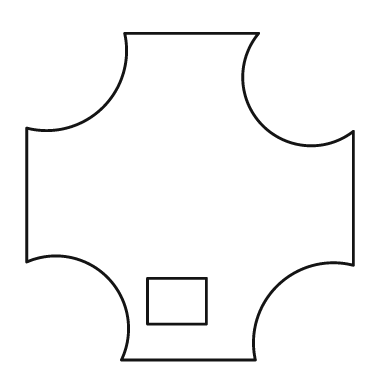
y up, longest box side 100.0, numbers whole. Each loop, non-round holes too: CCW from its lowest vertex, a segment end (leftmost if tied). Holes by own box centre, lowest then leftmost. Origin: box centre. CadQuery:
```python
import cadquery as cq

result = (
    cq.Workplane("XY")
    .moveTo(-21.0, -50.0)
    .lineTo(20.0, -50.0)
    .threePointArc((27.0, -27.0), (50.0, -21.0))
    .lineTo(50.0, 20.0)
    .threePointArc((22.0, 22.0), (21.0, 50.0))
    .lineTo(-20.0, 50.0)
    .threePointArc((-27.0, 27.0), (-50.0, 21.0))
    .lineTo(-50.0, -20.0)
    .threePointArc((-25.0, -25.0), (-21.0, -50.0))
    .close()
    .moveTo(-13.0, -39.0)
    .lineTo(5.0, -39.0)
    .lineTo(5.0, -25.0)
    .lineTo(-13.0, -25.0)
    .close()
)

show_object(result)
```